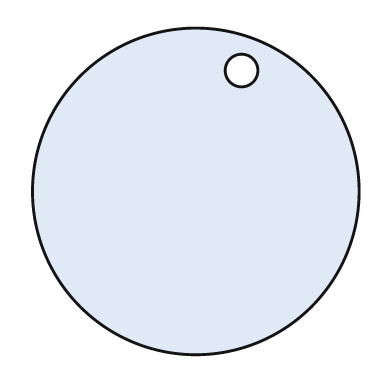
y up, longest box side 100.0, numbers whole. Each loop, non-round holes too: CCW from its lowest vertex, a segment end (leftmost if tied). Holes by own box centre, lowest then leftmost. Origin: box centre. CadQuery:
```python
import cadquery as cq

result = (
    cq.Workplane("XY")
    .moveTo(0.0, 0.0)
    .circle(50.0)
    .moveTo(14.0, 37.0)
    .circle(5.0)
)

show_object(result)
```